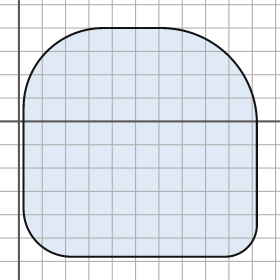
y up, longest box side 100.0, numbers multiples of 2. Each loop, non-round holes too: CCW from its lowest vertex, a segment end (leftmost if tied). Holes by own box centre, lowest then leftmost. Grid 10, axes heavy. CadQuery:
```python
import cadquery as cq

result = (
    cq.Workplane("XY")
    .moveTo(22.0, -58.0)
    .lineTo(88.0, -58.0)
    .threePointArc((98.0, -54.0), (102.0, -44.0))
    .lineTo(102.0, 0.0)
    .threePointArc((90.0, 28.0), (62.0, 40.0))
    .lineTo(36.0, 40.0)
    .threePointArc((12.0, 30.0), (2.0, 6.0))
    .lineTo(2.0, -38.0)
    .threePointArc((8.0, -52.0), (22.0, -58.0))
    .close()
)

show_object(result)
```